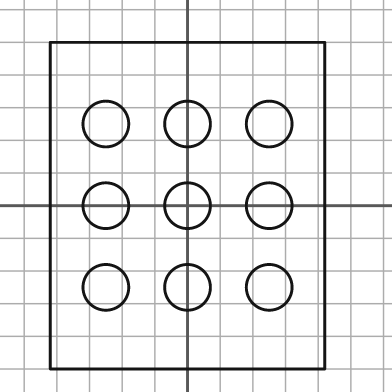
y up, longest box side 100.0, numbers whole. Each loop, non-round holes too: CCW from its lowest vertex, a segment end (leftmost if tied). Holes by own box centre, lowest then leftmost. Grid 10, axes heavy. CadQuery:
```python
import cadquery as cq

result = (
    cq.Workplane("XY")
    .moveTo(-42.0, -50.0)
    .lineTo(42.0, -50.0)
    .lineTo(42.0, 50.0)
    .lineTo(-42.0, 50.0)
    .close()
    .moveTo(-25.0, -25.0)
    .circle(7.0)
    .moveTo(0.0, -25.0)
    .circle(7.0)
    .moveTo(25.0, -25.0)
    .circle(7.0)
    .moveTo(-25.0, 0.0)
    .circle(7.0)
    .moveTo(0.0, 0.0)
    .circle(7.0)
    .moveTo(25.0, 0.0)
    .circle(7.0)
    .moveTo(-25.0, 25.0)
    .circle(7.0)
    .moveTo(0.0, 25.0)
    .circle(7.0)
    .moveTo(25.0, 25.0)
    .circle(7.0)
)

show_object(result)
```